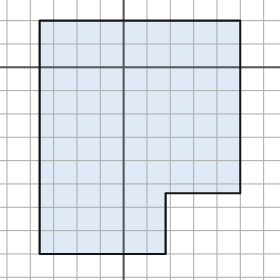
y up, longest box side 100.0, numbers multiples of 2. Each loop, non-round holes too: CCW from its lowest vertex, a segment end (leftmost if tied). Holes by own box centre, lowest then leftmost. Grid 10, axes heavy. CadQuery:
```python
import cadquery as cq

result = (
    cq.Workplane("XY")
    .moveTo(-36.0, -80.0)
    .lineTo(18.0, -80.0)
    .lineTo(18.0, -54.0)
    .lineTo(50.0, -54.0)
    .lineTo(50.0, 20.0)
    .lineTo(-36.0, 20.0)
    .close()
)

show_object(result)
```